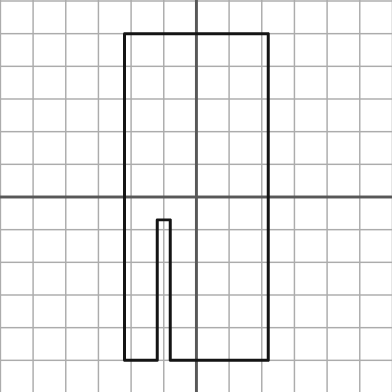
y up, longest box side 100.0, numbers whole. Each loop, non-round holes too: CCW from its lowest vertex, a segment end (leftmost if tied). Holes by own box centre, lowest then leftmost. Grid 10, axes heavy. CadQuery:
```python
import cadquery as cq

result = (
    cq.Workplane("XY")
    .moveTo(-22.0, -50.0)
    .lineTo(-12.0, -50.0)
    .lineTo(-12.0, -7.0)
    .lineTo(-8.0, -7.0)
    .lineTo(-8.0, -50.0)
    .lineTo(22.0, -50.0)
    .lineTo(22.0, 50.0)
    .lineTo(-22.0, 50.0)
    .close()
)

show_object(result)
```